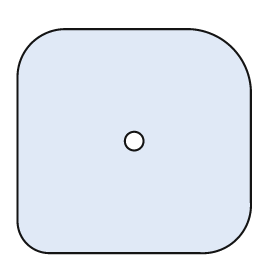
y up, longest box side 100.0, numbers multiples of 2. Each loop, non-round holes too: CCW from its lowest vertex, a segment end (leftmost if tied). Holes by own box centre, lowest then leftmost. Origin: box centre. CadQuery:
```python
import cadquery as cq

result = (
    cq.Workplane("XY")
    .moveTo(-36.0, -48.0)
    .lineTo(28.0, -48.0)
    .threePointArc((44.0, -42.0), (50.0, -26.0))
    .lineTo(50.0, 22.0)
    .threePointArc((42.0, 40.0), (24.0, 48.0))
    .lineTo(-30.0, 48.0)
    .threePointArc((-44.0, 42.0), (-50.0, 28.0))
    .lineTo(-50.0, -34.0)
    .threePointArc((-46.0, -44.0), (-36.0, -48.0))
    .close()
    .moveTo(0.0, 0.0)
    .circle(4.0)
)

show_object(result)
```